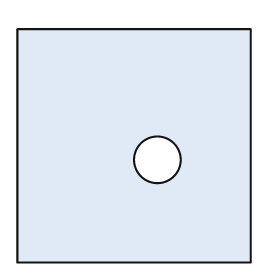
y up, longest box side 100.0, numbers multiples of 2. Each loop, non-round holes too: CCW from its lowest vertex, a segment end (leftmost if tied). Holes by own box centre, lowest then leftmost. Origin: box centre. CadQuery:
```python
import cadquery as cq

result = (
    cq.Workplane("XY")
    .moveTo(-50.0, -50.0)
    .lineTo(50.0, -50.0)
    .lineTo(50.0, 50.0)
    .lineTo(-50.0, 50.0)
    .close()
    .moveTo(10.0, -6.0)
    .circle(10.0)
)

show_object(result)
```